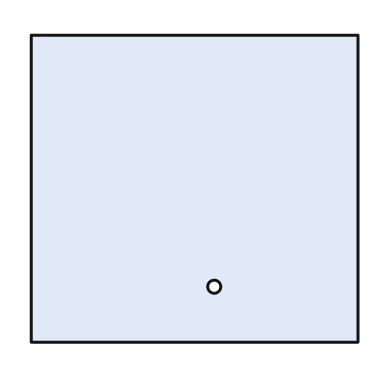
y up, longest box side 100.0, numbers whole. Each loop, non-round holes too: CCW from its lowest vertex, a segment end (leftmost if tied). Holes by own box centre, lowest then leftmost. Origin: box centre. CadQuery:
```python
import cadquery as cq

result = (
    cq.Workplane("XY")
    .moveTo(-50.0, -47.0)
    .lineTo(50.0, -47.0)
    .lineTo(50.0, 47.0)
    .lineTo(-50.0, 47.0)
    .close()
    .moveTo(6.0, -30.0)
    .circle(2.0)
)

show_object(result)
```